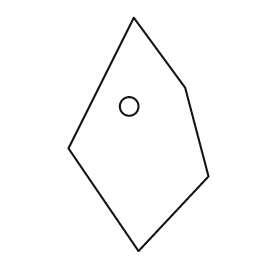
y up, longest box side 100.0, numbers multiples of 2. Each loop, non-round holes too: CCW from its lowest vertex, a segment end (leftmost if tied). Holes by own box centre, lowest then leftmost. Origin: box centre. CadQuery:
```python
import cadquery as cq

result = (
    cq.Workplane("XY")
    .moveTo(0.0, -50.0)
    .lineTo(30.0, -18.0)
    .lineTo(20.0, 20.0)
    .lineTo(-2.0, 50.0)
    .lineTo(-30.0, -6.0)
    .close()
    .moveTo(-4.0, 12.0)
    .circle(4.0)
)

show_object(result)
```